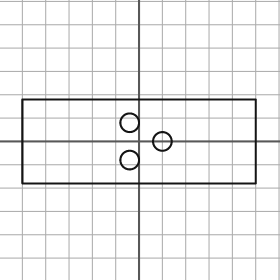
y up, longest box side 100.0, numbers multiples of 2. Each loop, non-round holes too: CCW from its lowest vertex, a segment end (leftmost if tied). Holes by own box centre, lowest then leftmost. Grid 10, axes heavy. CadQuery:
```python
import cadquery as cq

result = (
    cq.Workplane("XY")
    .moveTo(-50.0, -18.0)
    .lineTo(50.0, -18.0)
    .lineTo(50.0, 18.0)
    .lineTo(-50.0, 18.0)
    .close()
    .moveTo(-4.0, -8.0)
    .circle(4.0)
    .moveTo(10.0, 0.0)
    .circle(4.0)
    .moveTo(-4.0, 8.0)
    .circle(4.0)
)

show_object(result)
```